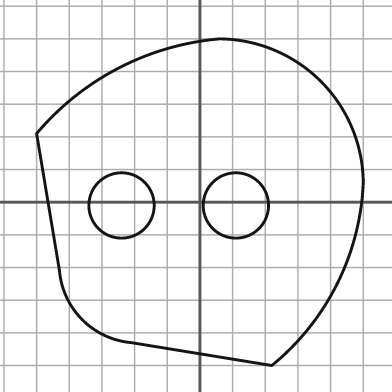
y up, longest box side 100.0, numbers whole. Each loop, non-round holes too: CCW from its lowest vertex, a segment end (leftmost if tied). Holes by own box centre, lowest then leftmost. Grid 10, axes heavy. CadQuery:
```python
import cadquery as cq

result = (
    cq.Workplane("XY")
    .moveTo(22.0, -50.0)
    .threePointArc((42.0, -25.0), (50.0, 6.0))
    .threePointArc((37.0, 37.0), (6.0, 50.0))
    .threePointArc((-25.0, 41.0), (-50.0, 21.0))
    .lineTo(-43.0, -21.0)
    .threePointArc((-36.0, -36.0), (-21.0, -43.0))
    .close()
    .moveTo(-24.0, -1.0)
    .circle(10.0)
    .moveTo(11.0, -1.0)
    .circle(10.0)
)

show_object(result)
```